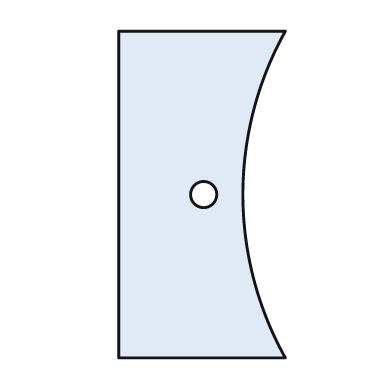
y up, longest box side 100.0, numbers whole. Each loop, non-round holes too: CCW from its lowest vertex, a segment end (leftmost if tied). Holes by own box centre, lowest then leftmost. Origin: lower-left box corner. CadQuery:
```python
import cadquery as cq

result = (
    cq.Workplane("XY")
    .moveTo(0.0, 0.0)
    .lineTo(51.0, 0.0)
    .threePointArc((38.0, 50.0), (51.0, 100.0))
    .lineTo(0.0, 100.0)
    .close()
    .moveTo(26.0, 50.0)
    .circle(4.0)
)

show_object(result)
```